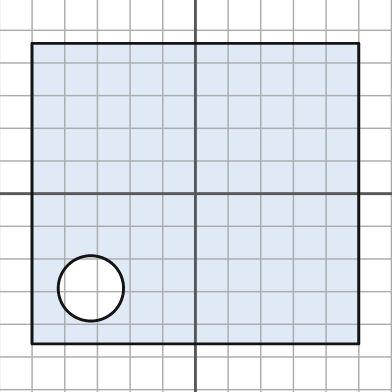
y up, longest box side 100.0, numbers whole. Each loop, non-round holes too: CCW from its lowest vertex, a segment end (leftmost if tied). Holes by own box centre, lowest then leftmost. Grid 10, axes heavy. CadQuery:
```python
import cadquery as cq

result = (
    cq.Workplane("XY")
    .moveTo(-50.0, -46.0)
    .lineTo(50.0, -46.0)
    .lineTo(50.0, 46.0)
    .lineTo(-50.0, 46.0)
    .close()
    .moveTo(-32.0, -29.0)
    .circle(10.0)
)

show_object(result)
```